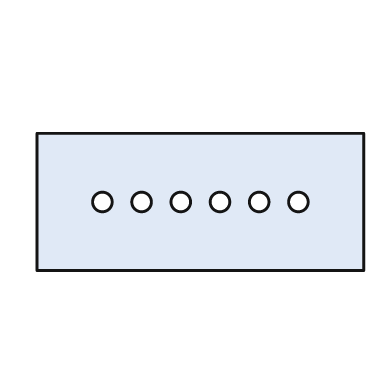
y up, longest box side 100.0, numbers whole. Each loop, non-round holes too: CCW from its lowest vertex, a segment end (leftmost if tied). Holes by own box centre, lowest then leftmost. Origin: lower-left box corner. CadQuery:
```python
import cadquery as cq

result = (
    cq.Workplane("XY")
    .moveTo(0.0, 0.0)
    .lineTo(100.0, 0.0)
    .lineTo(100.0, 42.0)
    .lineTo(0.0, 42.0)
    .close()
    .moveTo(20.0, 21.0)
    .circle(3.0)
    .moveTo(32.0, 21.0)
    .circle(3.0)
    .moveTo(44.0, 21.0)
    .circle(3.0)
    .moveTo(56.0, 21.0)
    .circle(3.0)
    .moveTo(68.0, 21.0)
    .circle(3.0)
    .moveTo(80.0, 21.0)
    .circle(3.0)
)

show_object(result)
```